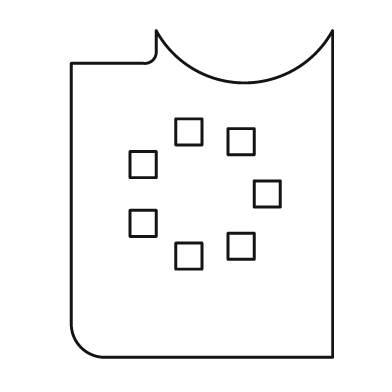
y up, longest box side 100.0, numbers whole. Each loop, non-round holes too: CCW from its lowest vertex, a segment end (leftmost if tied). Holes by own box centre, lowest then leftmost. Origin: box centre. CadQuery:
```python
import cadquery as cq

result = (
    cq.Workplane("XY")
    .moveTo(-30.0, -50.0)
    .lineTo(40.0, -50.0)
    .lineTo(40.0, 50.0)
    .threePointArc((13.0, 34.0), (-14.0, 50.0))
    .lineTo(-14.0, 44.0)
    .threePointArc((-15.0, 41.0), (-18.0, 40.0))
    .lineTo(-40.0, 40.0)
    .lineTo(-40.0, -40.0)
    .threePointArc((-37.0, -47.0), (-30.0, -50.0))
    .close()
    .moveTo(-8.0, -23.0)
    .lineTo(0.0, -23.0)
    .lineTo(0.0, -15.0)
    .lineTo(-8.0, -15.0)
    .close()
    .moveTo(8.0, -20.0)
    .lineTo(16.0, -20.0)
    .lineTo(16.0, -12.0)
    .lineTo(8.0, -12.0)
    .close()
    .moveTo(-22.0, -13.0)
    .lineTo(-14.0, -13.0)
    .lineTo(-14.0, -5.0)
    .lineTo(-22.0, -5.0)
    .close()
    .moveTo(16.0, -4.0)
    .lineTo(24.0, -4.0)
    .lineTo(24.0, 4.0)
    .lineTo(16.0, 4.0)
    .close()
    .moveTo(-22.0, 5.0)
    .lineTo(-14.0, 5.0)
    .lineTo(-14.0, 13.0)
    .lineTo(-22.0, 13.0)
    .close()
    .moveTo(8.0, 12.0)
    .lineTo(16.0, 12.0)
    .lineTo(16.0, 20.0)
    .lineTo(8.0, 20.0)
    .close()
    .moveTo(-8.0, 15.0)
    .lineTo(0.0, 15.0)
    .lineTo(0.0, 23.0)
    .lineTo(-8.0, 23.0)
    .close()
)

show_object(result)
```